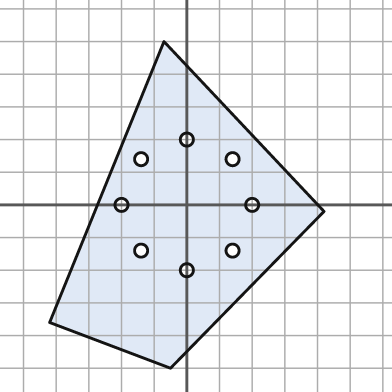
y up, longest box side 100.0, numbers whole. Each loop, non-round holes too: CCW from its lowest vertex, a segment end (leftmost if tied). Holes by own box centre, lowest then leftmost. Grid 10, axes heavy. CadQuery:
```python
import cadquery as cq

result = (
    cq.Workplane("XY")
    .moveTo(-5.0, -50.0)
    .lineTo(42.0, -2.0)
    .lineTo(-7.0, 50.0)
    .lineTo(-42.0, -36.0)
    .close()
    .moveTo(0.0, -20.0)
    .circle(2.0)
    .moveTo(-14.0, -14.0)
    .circle(2.0)
    .moveTo(14.0, -14.0)
    .circle(2.0)
    .moveTo(-20.0, 0.0)
    .circle(2.0)
    .moveTo(20.0, 0.0)
    .circle(2.0)
    .moveTo(-14.0, 14.0)
    .circle(2.0)
    .moveTo(14.0, 14.0)
    .circle(2.0)
    .moveTo(0.0, 20.0)
    .circle(2.0)
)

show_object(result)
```